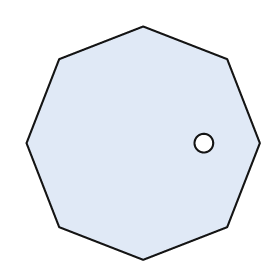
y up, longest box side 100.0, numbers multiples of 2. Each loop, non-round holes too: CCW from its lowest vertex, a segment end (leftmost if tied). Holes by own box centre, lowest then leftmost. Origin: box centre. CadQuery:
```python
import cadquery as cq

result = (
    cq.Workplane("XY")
    .moveTo(0.0, -50.0)
    .lineTo(36.0, -36.0)
    .lineTo(50.0, 0.0)
    .lineTo(36.0, 36.0)
    .lineTo(0.0, 50.0)
    .lineTo(-36.0, 36.0)
    .lineTo(-50.0, 0.0)
    .lineTo(-36.0, -36.0)
    .close()
    .moveTo(26.0, 0.0)
    .circle(4.0)
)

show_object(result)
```